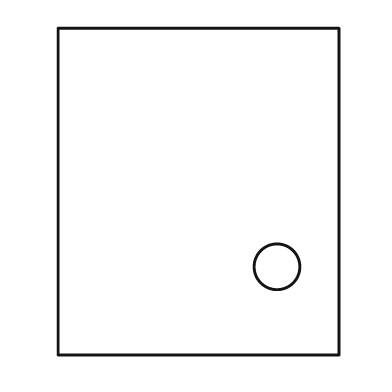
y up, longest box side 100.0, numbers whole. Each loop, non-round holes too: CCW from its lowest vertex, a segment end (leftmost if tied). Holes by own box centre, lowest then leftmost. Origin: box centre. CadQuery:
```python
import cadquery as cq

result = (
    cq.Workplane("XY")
    .moveTo(-43.0, -50.0)
    .lineTo(43.0, -50.0)
    .lineTo(43.0, 50.0)
    .lineTo(-43.0, 50.0)
    .close()
    .moveTo(24.0, -23.0)
    .circle(7.0)
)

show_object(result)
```